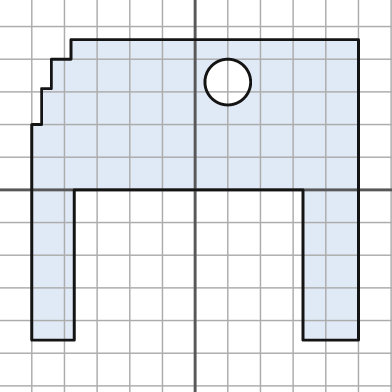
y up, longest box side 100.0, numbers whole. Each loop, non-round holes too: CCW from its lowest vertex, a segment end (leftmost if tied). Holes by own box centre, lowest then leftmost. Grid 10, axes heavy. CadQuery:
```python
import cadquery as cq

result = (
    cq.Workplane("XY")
    .moveTo(-50.0, -46.0)
    .lineTo(-37.0, -46.0)
    .lineTo(-37.0, 0.0)
    .lineTo(33.0, 0.0)
    .lineTo(33.0, -46.0)
    .lineTo(50.0, -46.0)
    .lineTo(50.0, 46.0)
    .lineTo(-38.0, 46.0)
    .lineTo(-38.0, 40.0)
    .lineTo(-44.0, 40.0)
    .lineTo(-44.0, 31.0)
    .lineTo(-47.0, 31.0)
    .lineTo(-47.0, 20.0)
    .lineTo(-50.0, 20.0)
    .close()
    .moveTo(10.0, 33.0)
    .circle(7.0)
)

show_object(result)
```